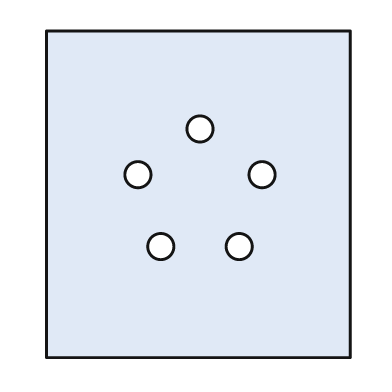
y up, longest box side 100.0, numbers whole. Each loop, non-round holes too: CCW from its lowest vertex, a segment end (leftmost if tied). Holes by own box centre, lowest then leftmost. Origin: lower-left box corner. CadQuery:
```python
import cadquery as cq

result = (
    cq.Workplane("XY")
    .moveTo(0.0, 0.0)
    .lineTo(93.0, 0.0)
    .lineTo(93.0, 100.0)
    .lineTo(0.0, 100.0)
    .close()
    .moveTo(35.0, 34.0)
    .circle(4.0)
    .moveTo(59.0, 34.0)
    .circle(4.0)
    .moveTo(28.0, 56.0)
    .circle(4.0)
    .moveTo(66.0, 56.0)
    .circle(4.0)
    .moveTo(47.0, 70.0)
    .circle(4.0)
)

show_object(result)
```